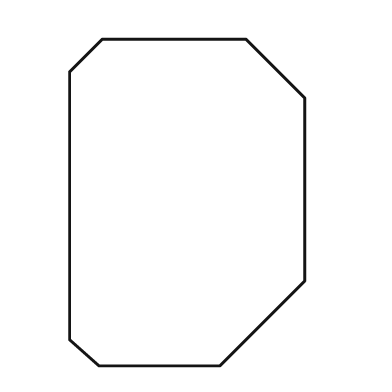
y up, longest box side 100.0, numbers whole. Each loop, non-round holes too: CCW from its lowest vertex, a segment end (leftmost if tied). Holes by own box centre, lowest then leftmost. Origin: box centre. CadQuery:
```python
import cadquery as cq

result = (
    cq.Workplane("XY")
    .moveTo(-27.0, -50.0)
    .lineTo(10.0, -50.0)
    .lineTo(36.0, -24.0)
    .lineTo(36.0, 32.0)
    .lineTo(18.0, 50.0)
    .lineTo(-26.0, 50.0)
    .lineTo(-36.0, 40.0)
    .lineTo(-36.0, -42.0)
    .close()
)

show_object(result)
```